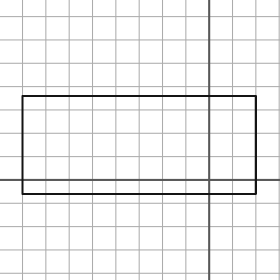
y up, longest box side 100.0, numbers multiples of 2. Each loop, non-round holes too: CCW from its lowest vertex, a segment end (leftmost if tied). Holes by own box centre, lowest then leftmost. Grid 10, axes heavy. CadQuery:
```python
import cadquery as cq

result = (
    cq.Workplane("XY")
    .moveTo(-80.0, -6.0)
    .lineTo(20.0, -6.0)
    .lineTo(20.0, 36.0)
    .lineTo(-80.0, 36.0)
    .close()
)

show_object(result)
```